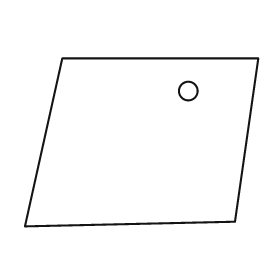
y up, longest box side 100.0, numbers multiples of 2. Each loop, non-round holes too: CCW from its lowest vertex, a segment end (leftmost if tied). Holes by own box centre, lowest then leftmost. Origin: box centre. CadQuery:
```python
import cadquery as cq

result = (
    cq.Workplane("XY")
    .moveTo(-50.0, -36.0)
    .lineTo(40.0, -34.0)
    .lineTo(50.0, 36.0)
    .lineTo(-34.0, 36.0)
    .close()
    .moveTo(20.0, 22.0)
    .circle(4.0)
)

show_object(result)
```